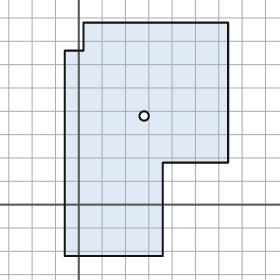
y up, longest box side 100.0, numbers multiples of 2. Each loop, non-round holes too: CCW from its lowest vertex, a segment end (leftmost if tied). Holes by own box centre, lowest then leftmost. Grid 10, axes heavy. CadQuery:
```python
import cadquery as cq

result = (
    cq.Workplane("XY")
    .moveTo(-6.0, -22.0)
    .lineTo(36.0, -22.0)
    .lineTo(36.0, 18.0)
    .lineTo(64.0, 18.0)
    .lineTo(64.0, 78.0)
    .lineTo(2.0, 78.0)
    .lineTo(2.0, 66.0)
    .lineTo(-6.0, 66.0)
    .close()
    .moveTo(28.0, 38.0)
    .circle(2.0)
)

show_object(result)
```